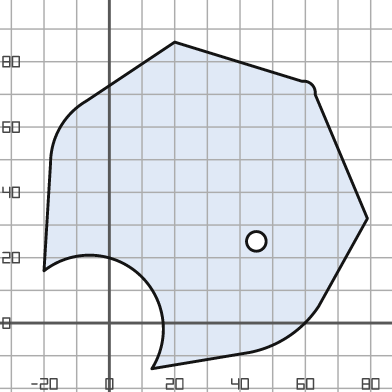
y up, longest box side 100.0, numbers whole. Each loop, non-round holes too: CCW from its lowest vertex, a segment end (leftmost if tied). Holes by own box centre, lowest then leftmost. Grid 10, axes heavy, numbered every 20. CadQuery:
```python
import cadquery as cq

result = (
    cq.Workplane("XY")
    .moveTo(13.0, -14.0)
    .lineTo(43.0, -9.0)
    .threePointArc((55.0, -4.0), (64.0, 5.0))
    .lineTo(79.0, 32.0)
    .lineTo(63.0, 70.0)
    .threePointArc((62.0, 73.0), (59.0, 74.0))
    .lineTo(20.0, 86.0)
    .lineTo(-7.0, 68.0)
    .threePointArc((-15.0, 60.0), (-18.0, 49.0))
    .lineTo(-20.0, 16.0)
    .threePointArc((9.0, 15.0), (13.0, -14.0))
    .close()
    .moveTo(45.0, 25.0)
    .circle(3.0)
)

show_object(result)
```